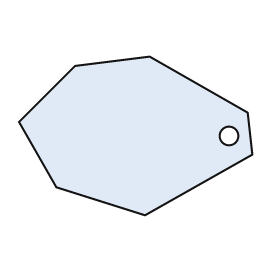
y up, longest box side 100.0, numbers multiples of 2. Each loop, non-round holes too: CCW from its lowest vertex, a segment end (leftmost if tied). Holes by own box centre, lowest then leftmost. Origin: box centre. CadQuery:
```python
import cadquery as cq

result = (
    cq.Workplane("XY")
    .moveTo(4.0, -34.0)
    .lineTo(50.0, -8.0)
    .lineTo(48.0, 10.0)
    .lineTo(6.0, 34.0)
    .lineTo(-26.0, 30.0)
    .lineTo(-50.0, 6.0)
    .lineTo(-34.0, -22.0)
    .close()
    .moveTo(40.0, 0.0)
    .circle(4.0)
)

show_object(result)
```